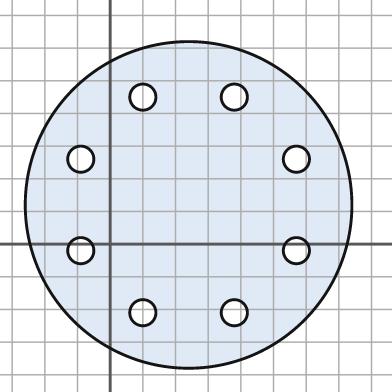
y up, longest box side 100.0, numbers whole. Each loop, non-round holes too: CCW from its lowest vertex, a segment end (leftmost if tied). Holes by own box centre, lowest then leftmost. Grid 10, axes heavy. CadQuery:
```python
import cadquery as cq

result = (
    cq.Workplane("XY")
    .moveTo(24.0, 12.0)
    .circle(50.0)
    .moveTo(10.0, -21.0)
    .circle(4.0)
    .moveTo(38.0, -21.0)
    .circle(4.0)
    .moveTo(-9.0, -2.0)
    .circle(4.0)
    .moveTo(57.0, -2.0)
    .circle(4.0)
    .moveTo(-9.0, 26.0)
    .circle(4.0)
    .moveTo(57.0, 26.0)
    .circle(4.0)
    .moveTo(10.0, 45.0)
    .circle(4.0)
    .moveTo(38.0, 45.0)
    .circle(4.0)
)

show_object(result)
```